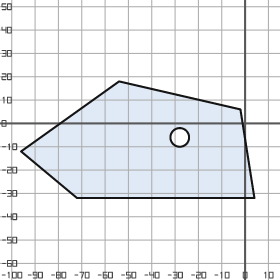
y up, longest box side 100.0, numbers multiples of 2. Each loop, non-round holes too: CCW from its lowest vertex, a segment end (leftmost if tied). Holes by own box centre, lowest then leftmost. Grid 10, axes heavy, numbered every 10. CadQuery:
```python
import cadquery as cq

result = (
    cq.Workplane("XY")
    .moveTo(-72.0, -32.0)
    .lineTo(4.0, -32.0)
    .lineTo(-2.0, 6.0)
    .lineTo(-54.0, 18.0)
    .lineTo(-96.0, -12.0)
    .close()
    .moveTo(-28.0, -6.0)
    .circle(4.0)
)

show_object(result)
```